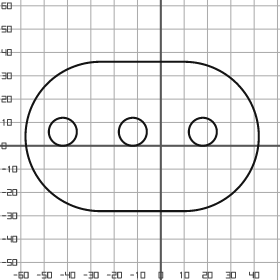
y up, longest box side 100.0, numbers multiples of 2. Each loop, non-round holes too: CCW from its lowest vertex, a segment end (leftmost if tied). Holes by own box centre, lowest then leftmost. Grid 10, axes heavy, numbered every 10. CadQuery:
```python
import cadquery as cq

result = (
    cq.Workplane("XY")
    .moveTo(-26.0, -28.0)
    .lineTo(10.0, -28.0)
    .threePointArc((42.0, 4.0), (10.0, 36.0))
    .lineTo(-26.0, 36.0)
    .threePointArc((-58.0, 4.0), (-26.0, -28.0))
    .close()
    .moveTo(-42.0, 6.0)
    .circle(6.0)
    .moveTo(-12.0, 6.0)
    .circle(6.0)
    .moveTo(18.0, 6.0)
    .circle(6.0)
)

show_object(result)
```